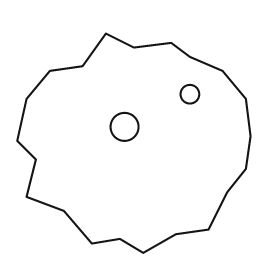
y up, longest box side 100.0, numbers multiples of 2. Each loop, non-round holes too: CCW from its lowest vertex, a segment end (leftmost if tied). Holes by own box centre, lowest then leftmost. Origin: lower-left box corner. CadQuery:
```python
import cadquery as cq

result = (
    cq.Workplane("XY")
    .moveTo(54.0, 0.0)
    .lineTo(68.0, 8.0)
    .lineTo(82.0, 10.0)
    .lineTo(90.0, 26.0)
    .lineTo(98.0, 36.0)
    .lineTo(100.0, 50.0)
    .lineTo(98.0, 66.0)
    .lineTo(88.0, 78.0)
    .lineTo(74.0, 84.0)
    .lineTo(66.0, 90.0)
    .lineTo(50.0, 88.0)
    .lineTo(38.0, 94.0)
    .lineTo(28.0, 80.0)
    .lineTo(14.0, 78.0)
    .lineTo(4.0, 66.0)
    .lineTo(0.0, 48.0)
    .lineTo(8.0, 40.0)
    .lineTo(4.0, 24.0)
    .lineTo(20.0, 18.0)
    .lineTo(32.0, 4.0)
    .lineTo(44.0, 6.0)
    .close()
    .moveTo(46.0, 54.0)
    .circle(6.0)
    .moveTo(74.0, 68.0)
    .circle(4.0)
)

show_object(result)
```